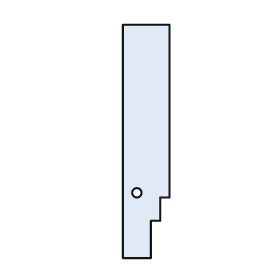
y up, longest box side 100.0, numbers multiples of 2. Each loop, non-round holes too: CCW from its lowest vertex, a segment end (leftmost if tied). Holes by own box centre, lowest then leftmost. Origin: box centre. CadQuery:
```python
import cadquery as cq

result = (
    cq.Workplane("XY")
    .moveTo(-10.0, -50.0)
    .lineTo(2.0, -50.0)
    .lineTo(2.0, -34.0)
    .lineTo(6.0, -34.0)
    .lineTo(6.0, -24.0)
    .lineTo(10.0, -24.0)
    .lineTo(10.0, 50.0)
    .lineTo(-10.0, 50.0)
    .close()
    .moveTo(-4.0, -22.0)
    .circle(2.0)
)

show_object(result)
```